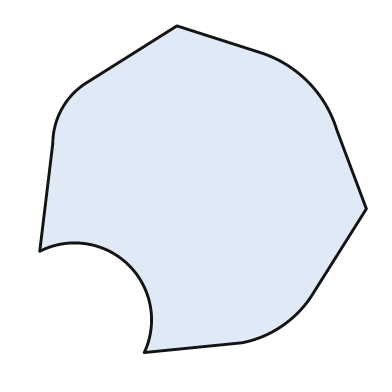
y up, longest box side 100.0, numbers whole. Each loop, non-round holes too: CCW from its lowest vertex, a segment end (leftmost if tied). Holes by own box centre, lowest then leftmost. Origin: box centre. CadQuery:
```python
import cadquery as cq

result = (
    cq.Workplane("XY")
    .moveTo(-18.0, -50.0)
    .lineTo(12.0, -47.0)
    .threePointArc((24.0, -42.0), (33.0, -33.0))
    .lineTo(50.0, -6.0)
    .lineTo(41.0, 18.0)
    .threePointArc((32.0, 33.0), (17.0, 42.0))
    .lineTo(-8.0, 50.0)
    .lineTo(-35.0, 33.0)
    .threePointArc((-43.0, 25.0), (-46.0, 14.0))
    .lineTo(-50.0, -19.0)
    .threePointArc((-23.0, -23.0), (-18.0, -50.0))
    .close()
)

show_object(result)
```